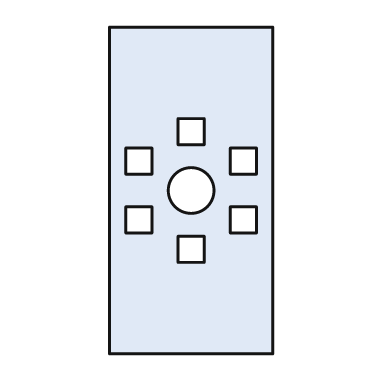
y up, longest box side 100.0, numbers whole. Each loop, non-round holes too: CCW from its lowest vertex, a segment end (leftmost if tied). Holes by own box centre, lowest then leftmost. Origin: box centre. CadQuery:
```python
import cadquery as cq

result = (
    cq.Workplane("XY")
    .moveTo(-25.0, -50.0)
    .lineTo(25.0, -50.0)
    .lineTo(25.0, 50.0)
    .lineTo(-25.0, 50.0)
    .close()
    .moveTo(-4.0, -22.0)
    .lineTo(4.0, -22.0)
    .lineTo(4.0, -14.0)
    .lineTo(-4.0, -14.0)
    .close()
    .moveTo(-20.0, -13.0)
    .lineTo(-12.0, -13.0)
    .lineTo(-12.0, -5.0)
    .lineTo(-20.0, -5.0)
    .close()
    .moveTo(12.0, -13.0)
    .lineTo(20.0, -13.0)
    .lineTo(20.0, -5.0)
    .lineTo(12.0, -5.0)
    .close()
    .moveTo(0.0, 0.0)
    .circle(7.0)
    .moveTo(-20.0, 5.0)
    .lineTo(-12.0, 5.0)
    .lineTo(-12.0, 13.0)
    .lineTo(-20.0, 13.0)
    .close()
    .moveTo(12.0, 5.0)
    .lineTo(20.0, 5.0)
    .lineTo(20.0, 13.0)
    .lineTo(12.0, 13.0)
    .close()
    .moveTo(-4.0, 14.0)
    .lineTo(4.0, 14.0)
    .lineTo(4.0, 22.0)
    .lineTo(-4.0, 22.0)
    .close()
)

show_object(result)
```